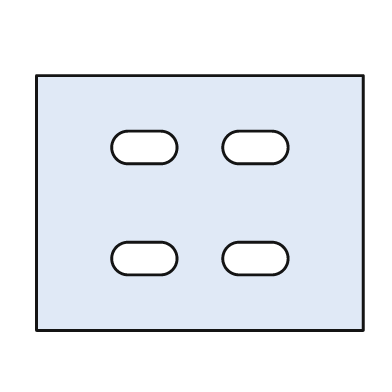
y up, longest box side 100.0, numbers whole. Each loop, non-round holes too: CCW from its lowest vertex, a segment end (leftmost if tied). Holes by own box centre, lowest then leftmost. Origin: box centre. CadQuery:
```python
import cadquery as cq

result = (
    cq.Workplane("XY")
    .moveTo(-50.0, -39.0)
    .lineTo(50.0, -39.0)
    .lineTo(50.0, 39.0)
    .lineTo(-50.0, 39.0)
    .close()
    .moveTo(-22.0, -22.0)
    .lineTo(-12.0, -22.0)
    .threePointArc((-7.0, -17.0), (-12.0, -12.0))
    .lineTo(-22.0, -12.0)
    .threePointArc((-27.0, -17.0), (-22.0, -22.0))
    .close()
    .moveTo(12.0, -22.0)
    .lineTo(22.0, -22.0)
    .threePointArc((27.0, -17.0), (22.0, -12.0))
    .lineTo(12.0, -12.0)
    .threePointArc((7.0, -17.0), (12.0, -22.0))
    .close()
    .moveTo(-22.0, 12.0)
    .lineTo(-12.0, 12.0)
    .threePointArc((-7.0, 17.0), (-12.0, 22.0))
    .lineTo(-22.0, 22.0)
    .threePointArc((-27.0, 17.0), (-22.0, 12.0))
    .close()
    .moveTo(12.0, 12.0)
    .lineTo(22.0, 12.0)
    .threePointArc((27.0, 17.0), (22.0, 22.0))
    .lineTo(12.0, 22.0)
    .threePointArc((7.0, 17.0), (12.0, 12.0))
    .close()
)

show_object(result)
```